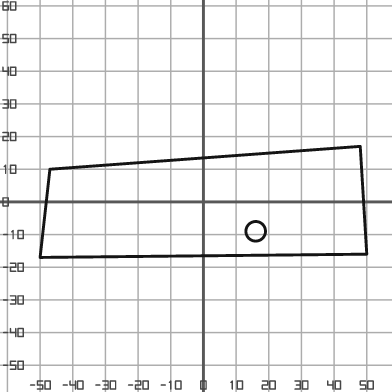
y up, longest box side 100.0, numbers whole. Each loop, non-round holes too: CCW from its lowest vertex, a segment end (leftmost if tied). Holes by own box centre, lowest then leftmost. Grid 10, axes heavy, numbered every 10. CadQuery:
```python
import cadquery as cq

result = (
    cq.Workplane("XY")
    .moveTo(-50.0, -17.0)
    .lineTo(50.0, -16.0)
    .lineTo(48.0, 17.0)
    .lineTo(-47.0, 10.0)
    .close()
    .moveTo(16.0, -9.0)
    .circle(3.0)
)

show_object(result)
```